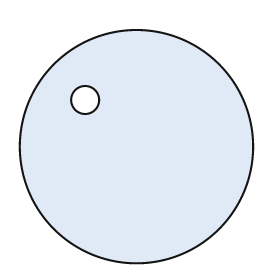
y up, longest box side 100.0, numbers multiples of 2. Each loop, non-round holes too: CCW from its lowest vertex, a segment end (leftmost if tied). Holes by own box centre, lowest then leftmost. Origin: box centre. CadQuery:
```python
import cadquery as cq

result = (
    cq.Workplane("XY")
    .moveTo(0.0, 0.0)
    .circle(50.0)
    .moveTo(-22.0, 20.0)
    .circle(6.0)
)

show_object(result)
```